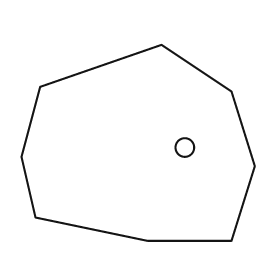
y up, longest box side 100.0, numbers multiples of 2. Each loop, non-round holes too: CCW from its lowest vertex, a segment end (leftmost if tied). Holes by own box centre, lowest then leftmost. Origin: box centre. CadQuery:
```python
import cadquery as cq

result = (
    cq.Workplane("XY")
    .moveTo(4.0, -42.0)
    .lineTo(40.0, -42.0)
    .lineTo(50.0, -10.0)
    .lineTo(40.0, 22.0)
    .lineTo(10.0, 42.0)
    .lineTo(-42.0, 24.0)
    .lineTo(-50.0, -6.0)
    .lineTo(-44.0, -32.0)
    .close()
    .moveTo(20.0, -2.0)
    .circle(4.0)
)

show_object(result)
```